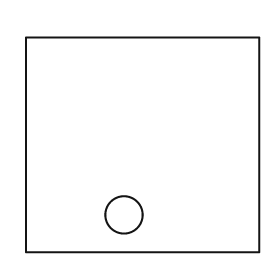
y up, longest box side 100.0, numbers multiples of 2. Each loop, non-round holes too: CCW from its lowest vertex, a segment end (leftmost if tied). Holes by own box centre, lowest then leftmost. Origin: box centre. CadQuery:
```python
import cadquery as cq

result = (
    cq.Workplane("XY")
    .moveTo(-50.0, -46.0)
    .lineTo(50.0, -46.0)
    .lineTo(50.0, 46.0)
    .lineTo(-50.0, 46.0)
    .close()
    .moveTo(-8.0, -30.0)
    .circle(8.0)
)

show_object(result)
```